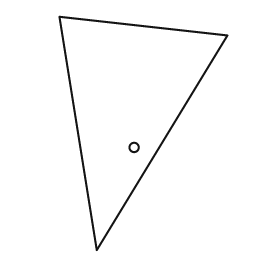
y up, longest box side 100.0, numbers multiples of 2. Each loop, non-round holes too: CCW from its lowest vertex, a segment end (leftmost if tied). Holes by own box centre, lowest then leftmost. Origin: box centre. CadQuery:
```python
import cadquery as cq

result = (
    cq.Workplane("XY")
    .moveTo(-20.0, -50.0)
    .lineTo(36.0, 42.0)
    .lineTo(-36.0, 50.0)
    .close()
    .moveTo(-4.0, -6.0)
    .circle(2.0)
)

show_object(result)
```